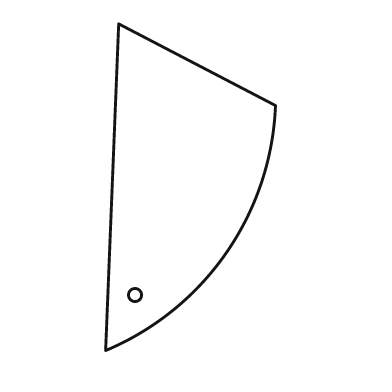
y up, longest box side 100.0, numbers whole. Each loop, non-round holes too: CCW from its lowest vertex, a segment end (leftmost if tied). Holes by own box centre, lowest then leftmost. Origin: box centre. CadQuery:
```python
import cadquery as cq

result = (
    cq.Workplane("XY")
    .moveTo(-26.0, -50.0)
    .threePointArc((11.0, -20.0), (26.0, 25.0))
    .lineTo(-22.0, 50.0)
    .close()
    .moveTo(-17.0, -33.0)
    .circle(2.0)
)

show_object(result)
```